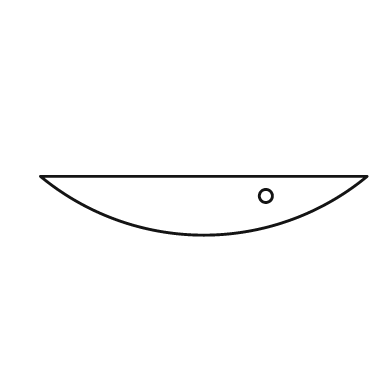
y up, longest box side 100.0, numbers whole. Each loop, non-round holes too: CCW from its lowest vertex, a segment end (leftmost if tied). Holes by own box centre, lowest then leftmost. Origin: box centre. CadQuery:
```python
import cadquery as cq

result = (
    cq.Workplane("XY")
    .moveTo(-50.0, 9.0)
    .threePointArc((0.0, -9.0), (50.0, 9.0))
    .close()
    .moveTo(19.0, 3.0)
    .circle(2.0)
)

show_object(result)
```